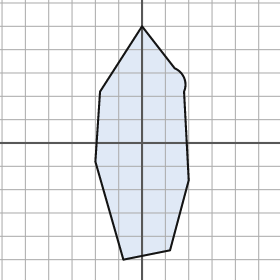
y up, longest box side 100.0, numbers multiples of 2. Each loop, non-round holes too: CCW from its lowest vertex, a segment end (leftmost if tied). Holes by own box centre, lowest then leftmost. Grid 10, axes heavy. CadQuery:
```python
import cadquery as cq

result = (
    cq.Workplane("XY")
    .moveTo(-8.0, -50.0)
    .lineTo(12.0, -46.0)
    .lineTo(20.0, -16.0)
    .lineTo(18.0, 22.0)
    .threePointArc((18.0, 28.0), (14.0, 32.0))
    .lineTo(0.0, 50.0)
    .lineTo(-18.0, 22.0)
    .lineTo(-20.0, -8.0)
    .close()
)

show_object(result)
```